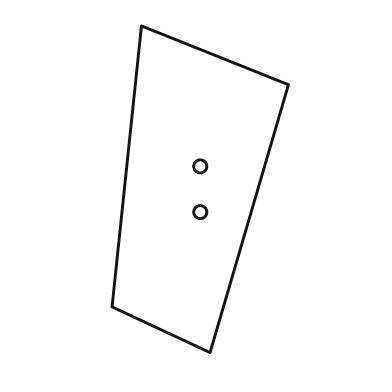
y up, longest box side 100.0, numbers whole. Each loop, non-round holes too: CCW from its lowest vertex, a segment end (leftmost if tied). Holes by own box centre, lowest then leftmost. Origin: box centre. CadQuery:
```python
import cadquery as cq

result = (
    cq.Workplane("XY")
    .moveTo(3.0, -50.0)
    .lineTo(27.0, 32.0)
    .lineTo(-18.0, 50.0)
    .lineTo(-27.0, -36.0)
    .close()
    .moveTo(0.0, -7.0)
    .circle(2.0)
    .moveTo(0.0, 7.0)
    .circle(2.0)
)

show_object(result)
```